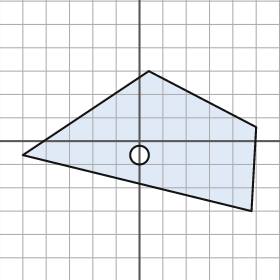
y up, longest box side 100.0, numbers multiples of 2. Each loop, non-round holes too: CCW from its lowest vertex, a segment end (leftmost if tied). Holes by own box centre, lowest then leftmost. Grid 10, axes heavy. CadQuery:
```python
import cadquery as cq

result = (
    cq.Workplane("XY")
    .moveTo(48.0, -30.0)
    .lineTo(50.0, 6.0)
    .lineTo(4.0, 30.0)
    .lineTo(-50.0, -6.0)
    .close()
    .moveTo(0.0, -6.0)
    .circle(4.0)
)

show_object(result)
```